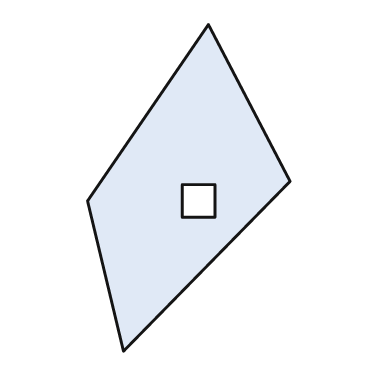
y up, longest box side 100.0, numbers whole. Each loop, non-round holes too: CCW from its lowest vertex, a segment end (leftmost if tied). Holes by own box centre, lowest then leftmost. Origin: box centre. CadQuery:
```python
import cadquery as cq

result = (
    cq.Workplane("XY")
    .moveTo(-20.0, -50.0)
    .lineTo(31.0, 2.0)
    .lineTo(6.0, 50.0)
    .lineTo(-31.0, -4.0)
    .close()
    .moveTo(-2.0, -9.0)
    .lineTo(8.0, -9.0)
    .lineTo(8.0, 1.0)
    .lineTo(-2.0, 1.0)
    .close()
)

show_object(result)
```